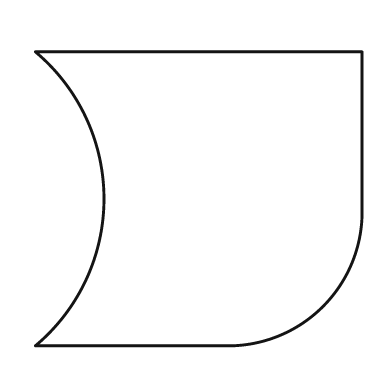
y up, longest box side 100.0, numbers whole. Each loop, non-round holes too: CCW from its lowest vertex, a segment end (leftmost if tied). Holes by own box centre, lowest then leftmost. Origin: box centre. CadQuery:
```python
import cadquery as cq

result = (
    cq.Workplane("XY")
    .moveTo(-50.0, -45.0)
    .lineTo(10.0, -45.0)
    .threePointArc((38.0, -33.0), (50.0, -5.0))
    .lineTo(50.0, 45.0)
    .lineTo(-50.0, 45.0)
    .threePointArc((-29.0, 0.0), (-50.0, -45.0))
    .close()
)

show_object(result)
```